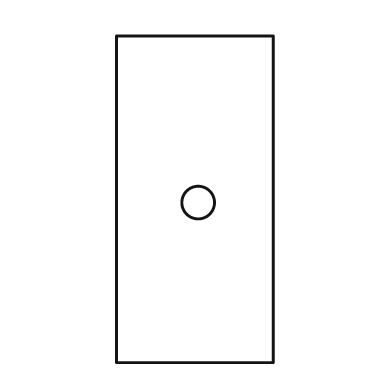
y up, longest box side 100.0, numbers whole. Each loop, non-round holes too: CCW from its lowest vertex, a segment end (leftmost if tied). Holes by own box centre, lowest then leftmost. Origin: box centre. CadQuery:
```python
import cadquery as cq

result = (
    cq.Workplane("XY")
    .moveTo(-24.0, -50.0)
    .lineTo(24.0, -50.0)
    .lineTo(24.0, 50.0)
    .lineTo(-24.0, 50.0)
    .close()
    .moveTo(1.0, -1.0)
    .circle(5.0)
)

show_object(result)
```